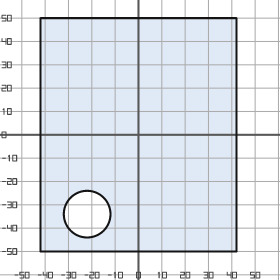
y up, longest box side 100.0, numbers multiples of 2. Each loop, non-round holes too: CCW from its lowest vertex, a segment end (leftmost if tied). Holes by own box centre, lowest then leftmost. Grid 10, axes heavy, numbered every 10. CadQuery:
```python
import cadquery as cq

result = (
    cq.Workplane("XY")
    .moveTo(-42.0, -50.0)
    .lineTo(42.0, -50.0)
    .lineTo(42.0, 50.0)
    .lineTo(-42.0, 50.0)
    .close()
    .moveTo(-22.0, -34.0)
    .circle(10.0)
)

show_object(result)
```